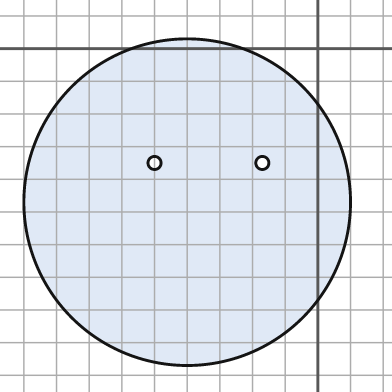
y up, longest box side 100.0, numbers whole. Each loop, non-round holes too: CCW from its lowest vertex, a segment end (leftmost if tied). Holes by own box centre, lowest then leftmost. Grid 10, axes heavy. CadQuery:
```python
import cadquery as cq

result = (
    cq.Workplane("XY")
    .moveTo(-40.0, -47.0)
    .circle(50.0)
    .moveTo(-50.0, -35.0)
    .circle(2.0)
    .moveTo(-17.0, -35.0)
    .circle(2.0)
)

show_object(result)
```